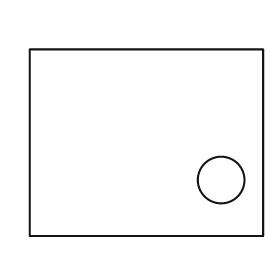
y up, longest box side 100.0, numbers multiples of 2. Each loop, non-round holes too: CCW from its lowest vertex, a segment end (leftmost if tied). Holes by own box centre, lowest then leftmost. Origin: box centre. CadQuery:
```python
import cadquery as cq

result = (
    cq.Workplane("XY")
    .moveTo(-50.0, -40.0)
    .lineTo(50.0, -40.0)
    .lineTo(50.0, 40.0)
    .lineTo(-50.0, 40.0)
    .close()
    .moveTo(32.0, -16.0)
    .circle(10.0)
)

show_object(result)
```